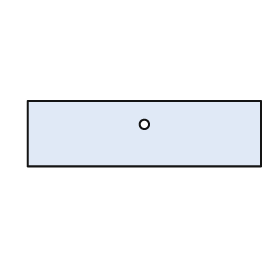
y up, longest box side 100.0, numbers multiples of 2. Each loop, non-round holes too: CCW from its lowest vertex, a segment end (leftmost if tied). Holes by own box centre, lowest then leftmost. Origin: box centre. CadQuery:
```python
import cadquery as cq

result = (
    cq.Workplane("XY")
    .moveTo(-50.0, -14.0)
    .lineTo(50.0, -14.0)
    .lineTo(50.0, 14.0)
    .lineTo(-50.0, 14.0)
    .close()
    .moveTo(0.0, 4.0)
    .circle(2.0)
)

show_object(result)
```